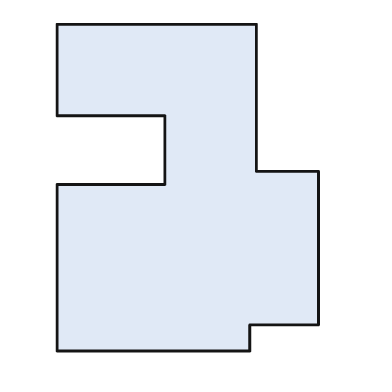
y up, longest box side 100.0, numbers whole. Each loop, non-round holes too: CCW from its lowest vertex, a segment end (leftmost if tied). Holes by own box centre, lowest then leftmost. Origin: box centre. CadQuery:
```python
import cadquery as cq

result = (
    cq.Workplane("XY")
    .moveTo(-40.0, -50.0)
    .lineTo(19.0, -50.0)
    .lineTo(19.0, -42.0)
    .lineTo(40.0, -42.0)
    .lineTo(40.0, 5.0)
    .lineTo(21.0, 5.0)
    .lineTo(21.0, 50.0)
    .lineTo(-40.0, 50.0)
    .lineTo(-40.0, 22.0)
    .lineTo(-7.0, 22.0)
    .lineTo(-7.0, 1.0)
    .lineTo(-40.0, 1.0)
    .close()
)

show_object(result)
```